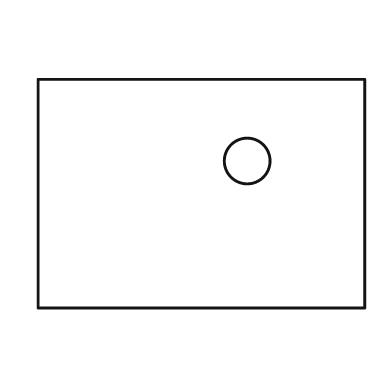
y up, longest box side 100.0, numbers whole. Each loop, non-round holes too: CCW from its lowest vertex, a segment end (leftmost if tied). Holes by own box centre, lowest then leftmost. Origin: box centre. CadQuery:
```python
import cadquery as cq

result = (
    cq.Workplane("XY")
    .moveTo(-50.0, -35.0)
    .lineTo(50.0, -35.0)
    .lineTo(50.0, 35.0)
    .lineTo(-50.0, 35.0)
    .close()
    .moveTo(14.0, 10.0)
    .circle(7.0)
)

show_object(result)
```